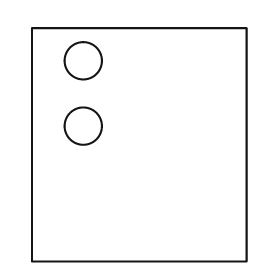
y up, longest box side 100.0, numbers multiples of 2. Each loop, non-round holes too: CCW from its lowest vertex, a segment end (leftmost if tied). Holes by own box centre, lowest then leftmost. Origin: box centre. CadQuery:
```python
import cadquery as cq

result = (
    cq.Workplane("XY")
    .moveTo(-46.0, -50.0)
    .lineTo(46.0, -50.0)
    .lineTo(46.0, 50.0)
    .lineTo(-46.0, 50.0)
    .close()
    .moveTo(-24.0, 8.0)
    .circle(8.0)
    .moveTo(-24.0, 36.0)
    .circle(8.0)
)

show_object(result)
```